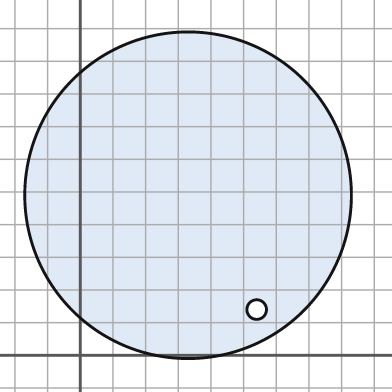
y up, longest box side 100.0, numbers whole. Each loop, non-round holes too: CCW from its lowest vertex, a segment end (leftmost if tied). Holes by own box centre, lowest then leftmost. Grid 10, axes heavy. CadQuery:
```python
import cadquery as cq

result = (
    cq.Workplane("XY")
    .moveTo(33.0, 49.0)
    .circle(50.0)
    .moveTo(54.0, 14.0)
    .circle(3.0)
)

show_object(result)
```